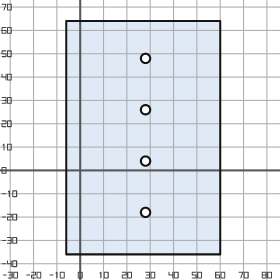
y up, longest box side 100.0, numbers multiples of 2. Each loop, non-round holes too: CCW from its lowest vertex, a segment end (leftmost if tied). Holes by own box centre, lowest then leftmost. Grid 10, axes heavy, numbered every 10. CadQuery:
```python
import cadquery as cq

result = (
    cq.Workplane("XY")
    .moveTo(-6.0, -36.0)
    .lineTo(60.0, -36.0)
    .lineTo(60.0, 64.0)
    .lineTo(-6.0, 64.0)
    .close()
    .moveTo(28.0, -18.0)
    .circle(2.0)
    .moveTo(28.0, 4.0)
    .circle(2.0)
    .moveTo(28.0, 26.0)
    .circle(2.0)
    .moveTo(28.0, 48.0)
    .circle(2.0)
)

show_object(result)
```